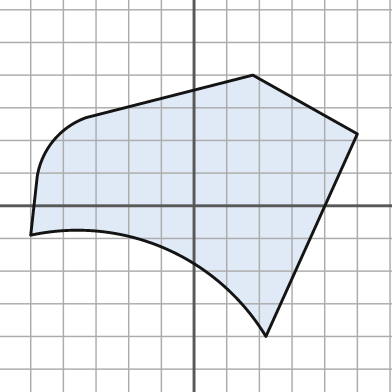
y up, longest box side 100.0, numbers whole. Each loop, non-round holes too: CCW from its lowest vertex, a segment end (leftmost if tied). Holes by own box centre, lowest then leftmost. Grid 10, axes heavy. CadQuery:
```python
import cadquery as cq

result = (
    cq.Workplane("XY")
    .moveTo(22.0, -40.0)
    .lineTo(50.0, 22.0)
    .lineTo(18.0, 40.0)
    .lineTo(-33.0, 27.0)
    .threePointArc((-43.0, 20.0), (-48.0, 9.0))
    .lineTo(-50.0, -9.0)
    .threePointArc((-9.0, -13.0), (22.0, -40.0))
    .close()
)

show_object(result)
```